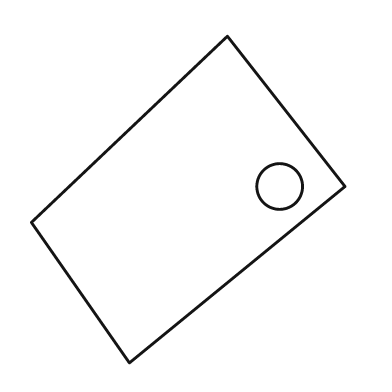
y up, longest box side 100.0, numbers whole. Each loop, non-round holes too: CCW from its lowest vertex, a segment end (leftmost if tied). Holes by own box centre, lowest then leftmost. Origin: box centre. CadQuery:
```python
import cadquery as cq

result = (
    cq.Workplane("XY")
    .moveTo(-18.0, -50.0)
    .lineTo(48.0, 4.0)
    .lineTo(12.0, 50.0)
    .lineTo(-48.0, -7.0)
    .close()
    .moveTo(28.0, 4.0)
    .circle(7.0)
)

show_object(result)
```